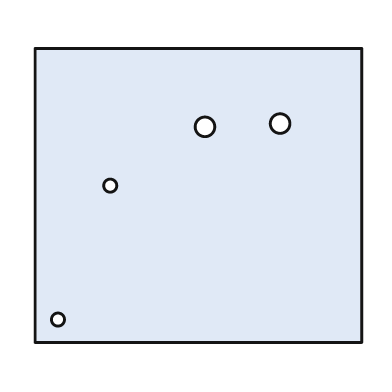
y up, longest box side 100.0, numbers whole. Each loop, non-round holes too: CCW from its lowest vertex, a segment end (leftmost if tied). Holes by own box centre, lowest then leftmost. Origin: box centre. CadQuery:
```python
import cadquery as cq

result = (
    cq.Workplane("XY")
    .moveTo(-50.0, -45.0)
    .lineTo(50.0, -45.0)
    .lineTo(50.0, 45.0)
    .lineTo(-50.0, 45.0)
    .close()
    .moveTo(-43.0, -38.0)
    .circle(2.0)
    .moveTo(-27.0, 3.0)
    .circle(2.0)
    .moveTo(2.0, 21.0)
    .circle(3.0)
    .moveTo(25.0, 22.0)
    .circle(3.0)
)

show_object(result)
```